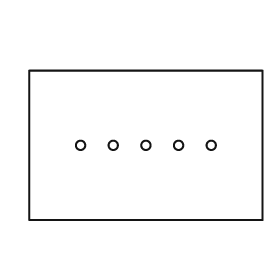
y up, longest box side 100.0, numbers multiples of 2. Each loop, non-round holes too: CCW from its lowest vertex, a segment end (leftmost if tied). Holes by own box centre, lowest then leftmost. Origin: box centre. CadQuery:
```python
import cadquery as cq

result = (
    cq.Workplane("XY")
    .moveTo(-50.0, -32.0)
    .lineTo(50.0, -32.0)
    .lineTo(50.0, 32.0)
    .lineTo(-50.0, 32.0)
    .close()
    .moveTo(-28.0, 0.0)
    .circle(2.0)
    .moveTo(-14.0, 0.0)
    .circle(2.0)
    .moveTo(0.0, 0.0)
    .circle(2.0)
    .moveTo(14.0, 0.0)
    .circle(2.0)
    .moveTo(28.0, 0.0)
    .circle(2.0)
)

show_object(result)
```